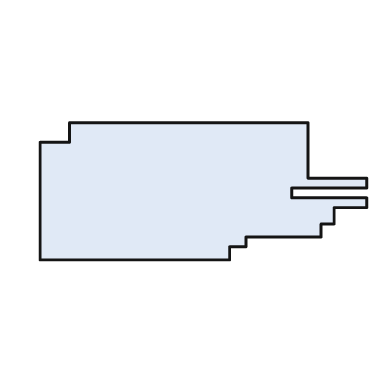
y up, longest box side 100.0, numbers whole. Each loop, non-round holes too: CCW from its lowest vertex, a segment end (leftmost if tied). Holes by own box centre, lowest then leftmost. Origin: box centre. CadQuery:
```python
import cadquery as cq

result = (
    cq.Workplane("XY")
    .moveTo(-50.0, -21.0)
    .lineTo(8.0, -21.0)
    .lineTo(8.0, -17.0)
    .lineTo(13.0, -17.0)
    .lineTo(13.0, -14.0)
    .lineTo(36.0, -14.0)
    .lineTo(36.0, -10.0)
    .lineTo(40.0, -10.0)
    .lineTo(40.0, -5.0)
    .lineTo(50.0, -5.0)
    .lineTo(50.0, -2.0)
    .lineTo(27.0, -2.0)
    .lineTo(27.0, 1.0)
    .lineTo(50.0, 1.0)
    .lineTo(50.0, 4.0)
    .lineTo(32.0, 4.0)
    .lineTo(32.0, 21.0)
    .lineTo(-41.0, 21.0)
    .lineTo(-41.0, 15.0)
    .lineTo(-50.0, 15.0)
    .close()
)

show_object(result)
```